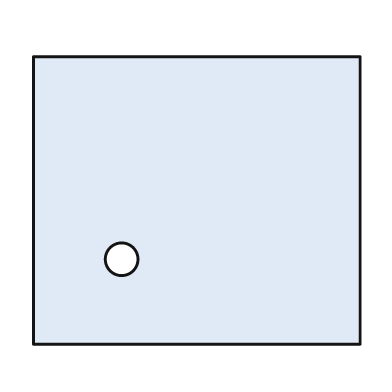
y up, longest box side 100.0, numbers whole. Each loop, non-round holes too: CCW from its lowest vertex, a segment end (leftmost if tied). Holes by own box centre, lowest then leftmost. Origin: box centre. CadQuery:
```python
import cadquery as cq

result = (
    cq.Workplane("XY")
    .moveTo(-50.0, -44.0)
    .lineTo(50.0, -44.0)
    .lineTo(50.0, 44.0)
    .lineTo(-50.0, 44.0)
    .close()
    .moveTo(-23.0, -18.0)
    .circle(5.0)
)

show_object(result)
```